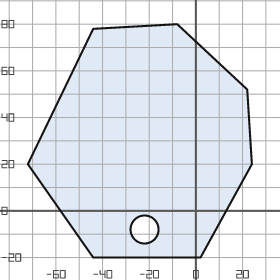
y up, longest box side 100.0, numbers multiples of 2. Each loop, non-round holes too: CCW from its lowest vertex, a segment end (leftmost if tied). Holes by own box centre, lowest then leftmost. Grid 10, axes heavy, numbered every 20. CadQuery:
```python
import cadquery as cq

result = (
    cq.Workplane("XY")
    .moveTo(-44.0, -20.0)
    .lineTo(2.0, -20.0)
    .lineTo(24.0, 20.0)
    .lineTo(22.0, 52.0)
    .lineTo(-8.0, 80.0)
    .lineTo(-44.0, 78.0)
    .lineTo(-72.0, 20.0)
    .close()
    .moveTo(-22.0, -8.0)
    .circle(6.0)
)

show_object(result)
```